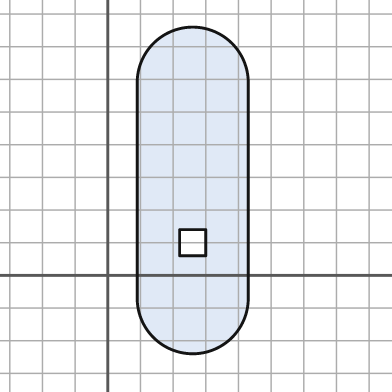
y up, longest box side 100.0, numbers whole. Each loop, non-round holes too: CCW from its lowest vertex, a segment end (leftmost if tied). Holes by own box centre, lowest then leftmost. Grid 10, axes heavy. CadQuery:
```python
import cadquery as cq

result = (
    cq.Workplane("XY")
    .moveTo(9.0, -7.0)
    .threePointArc((26.0, -24.0), (43.0, -7.0))
    .lineTo(43.0, 59.0)
    .threePointArc((26.0, 76.0), (9.0, 59.0))
    .close()
    .moveTo(22.0, 6.0)
    .lineTo(30.0, 6.0)
    .lineTo(30.0, 14.0)
    .lineTo(22.0, 14.0)
    .close()
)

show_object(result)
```